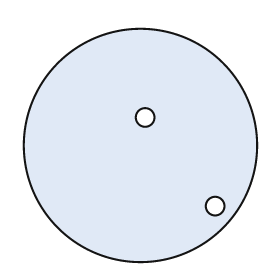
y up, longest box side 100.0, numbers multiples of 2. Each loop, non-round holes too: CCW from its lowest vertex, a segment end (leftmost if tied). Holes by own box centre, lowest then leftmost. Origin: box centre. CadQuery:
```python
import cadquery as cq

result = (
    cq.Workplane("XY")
    .moveTo(0.0, 0.0)
    .circle(50.0)
    .moveTo(32.0, -26.0)
    .circle(4.0)
    .moveTo(2.0, 12.0)
    .circle(4.0)
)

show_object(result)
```